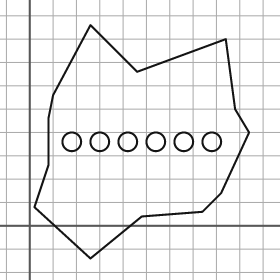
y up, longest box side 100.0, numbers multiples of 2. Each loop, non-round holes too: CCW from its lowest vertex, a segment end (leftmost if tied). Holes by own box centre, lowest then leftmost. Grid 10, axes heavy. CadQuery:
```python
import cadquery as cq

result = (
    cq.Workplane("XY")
    .moveTo(26.0, -14.0)
    .lineTo(48.0, 4.0)
    .lineTo(74.0, 6.0)
    .lineTo(82.0, 14.0)
    .lineTo(94.0, 40.0)
    .lineTo(88.0, 50.0)
    .lineTo(84.0, 80.0)
    .lineTo(46.0, 66.0)
    .lineTo(26.0, 86.0)
    .lineTo(10.0, 56.0)
    .lineTo(8.0, 46.0)
    .lineTo(8.0, 26.0)
    .lineTo(2.0, 8.0)
    .close()
    .moveTo(18.0, 36.0)
    .circle(4.0)
    .moveTo(30.0, 36.0)
    .circle(4.0)
    .moveTo(42.0, 36.0)
    .circle(4.0)
    .moveTo(54.0, 36.0)
    .circle(4.0)
    .moveTo(66.0, 36.0)
    .circle(4.0)
    .moveTo(78.0, 36.0)
    .circle(4.0)
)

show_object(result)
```